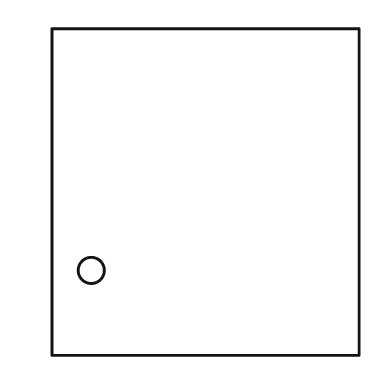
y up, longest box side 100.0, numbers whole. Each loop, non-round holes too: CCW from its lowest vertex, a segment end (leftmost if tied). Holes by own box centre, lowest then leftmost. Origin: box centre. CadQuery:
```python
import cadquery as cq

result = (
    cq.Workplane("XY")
    .moveTo(-47.0, -50.0)
    .lineTo(47.0, -50.0)
    .lineTo(47.0, 50.0)
    .lineTo(-47.0, 50.0)
    .close()
    .moveTo(-35.0, -24.0)
    .circle(4.0)
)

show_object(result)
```